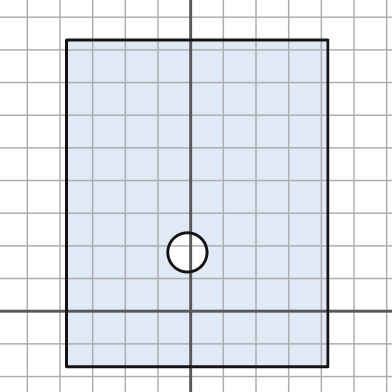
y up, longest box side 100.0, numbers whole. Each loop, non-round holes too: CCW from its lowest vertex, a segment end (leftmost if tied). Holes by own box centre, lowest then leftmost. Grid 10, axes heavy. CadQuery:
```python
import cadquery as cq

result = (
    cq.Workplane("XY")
    .moveTo(-38.0, -17.0)
    .lineTo(42.0, -17.0)
    .lineTo(42.0, 83.0)
    .lineTo(-38.0, 83.0)
    .close()
    .moveTo(-1.0, 18.0)
    .circle(6.0)
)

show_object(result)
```